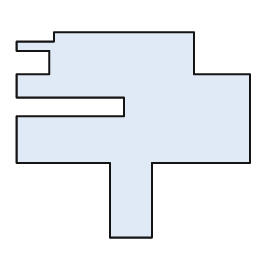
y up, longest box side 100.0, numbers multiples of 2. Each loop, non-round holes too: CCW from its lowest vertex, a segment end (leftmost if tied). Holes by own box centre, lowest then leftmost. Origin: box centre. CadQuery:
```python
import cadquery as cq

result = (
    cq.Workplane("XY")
    .moveTo(-10.0, -44.0)
    .lineTo(8.0, -44.0)
    .lineTo(8.0, -12.0)
    .lineTo(50.0, -12.0)
    .lineTo(50.0, 26.0)
    .lineTo(26.0, 26.0)
    .lineTo(26.0, 44.0)
    .lineTo(-34.0, 44.0)
    .lineTo(-34.0, 40.0)
    .lineTo(-50.0, 40.0)
    .lineTo(-50.0, 36.0)
    .lineTo(-36.0, 36.0)
    .lineTo(-36.0, 26.0)
    .lineTo(-50.0, 26.0)
    .lineTo(-50.0, 16.0)
    .lineTo(-4.0, 16.0)
    .lineTo(-4.0, 8.0)
    .lineTo(-50.0, 8.0)
    .lineTo(-50.0, -12.0)
    .lineTo(-10.0, -12.0)
    .close()
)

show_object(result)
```